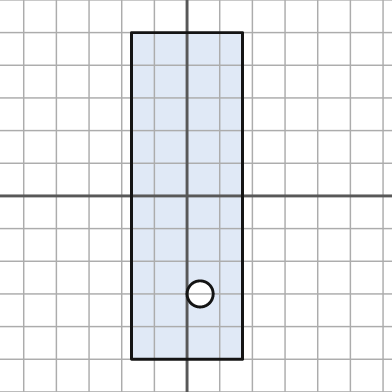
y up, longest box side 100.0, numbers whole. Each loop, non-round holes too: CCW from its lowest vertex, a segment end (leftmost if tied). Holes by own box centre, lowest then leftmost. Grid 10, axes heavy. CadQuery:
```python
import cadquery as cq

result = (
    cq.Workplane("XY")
    .moveTo(-17.0, -50.0)
    .lineTo(17.0, -50.0)
    .lineTo(17.0, 50.0)
    .lineTo(-17.0, 50.0)
    .close()
    .moveTo(4.0, -30.0)
    .circle(4.0)
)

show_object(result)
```